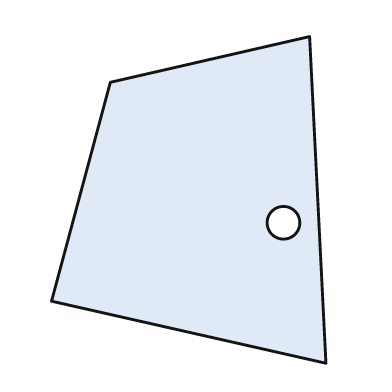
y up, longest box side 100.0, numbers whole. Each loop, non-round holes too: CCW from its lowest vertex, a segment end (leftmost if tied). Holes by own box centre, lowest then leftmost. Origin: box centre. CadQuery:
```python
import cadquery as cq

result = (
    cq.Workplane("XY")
    .moveTo(42.0, -50.0)
    .lineTo(37.0, 50.0)
    .lineTo(-24.0, 36.0)
    .lineTo(-42.0, -31.0)
    .close()
    .moveTo(29.0, -7.0)
    .circle(5.0)
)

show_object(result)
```